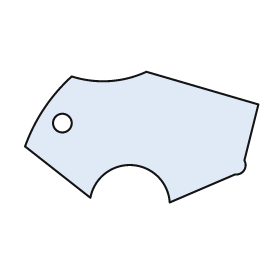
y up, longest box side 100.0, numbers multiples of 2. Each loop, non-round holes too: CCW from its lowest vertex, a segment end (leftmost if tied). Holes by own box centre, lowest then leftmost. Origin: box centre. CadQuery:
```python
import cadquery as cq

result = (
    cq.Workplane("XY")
    .moveTo(12.0, -28.0)
    .lineTo(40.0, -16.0)
    .threePointArc((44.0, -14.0), (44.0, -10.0))
    .lineTo(50.0, 14.0)
    .lineTo(2.0, 28.0)
    .threePointArc((-14.0, 24.0), (-30.0, 26.0))
    .threePointArc((-42.0, 12.0), (-50.0, -4.0))
    .lineTo(-22.0, -26.0)
    .threePointArc((-4.0, -12.0), (12.0, -28.0))
    .close()
    .moveTo(-34.0, 6.0)
    .circle(4.0)
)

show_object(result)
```